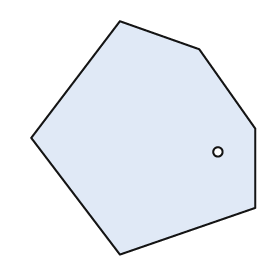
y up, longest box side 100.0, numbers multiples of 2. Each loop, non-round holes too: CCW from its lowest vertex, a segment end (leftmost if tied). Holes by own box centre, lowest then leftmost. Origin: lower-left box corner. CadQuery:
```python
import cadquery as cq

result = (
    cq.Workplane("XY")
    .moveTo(38.0, 0.0)
    .lineTo(96.0, 20.0)
    .lineTo(96.0, 54.0)
    .lineTo(72.0, 88.0)
    .lineTo(38.0, 100.0)
    .lineTo(0.0, 50.0)
    .close()
    .moveTo(80.0, 44.0)
    .circle(2.0)
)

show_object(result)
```